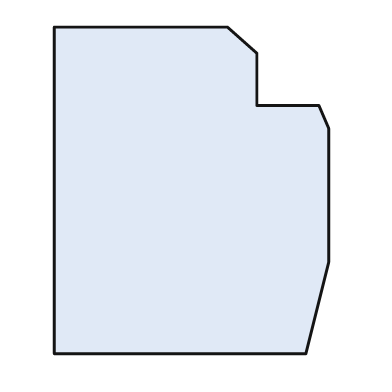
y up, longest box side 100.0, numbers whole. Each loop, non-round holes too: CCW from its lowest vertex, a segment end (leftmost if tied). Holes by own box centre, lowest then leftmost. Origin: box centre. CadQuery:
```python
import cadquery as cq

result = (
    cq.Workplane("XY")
    .moveTo(-42.0, -50.0)
    .lineTo(35.0, -50.0)
    .lineTo(42.0, -22.0)
    .lineTo(42.0, 19.0)
    .lineTo(39.0, 26.0)
    .lineTo(20.0, 26.0)
    .lineTo(20.0, 42.0)
    .lineTo(11.0, 50.0)
    .lineTo(-42.0, 50.0)
    .close()
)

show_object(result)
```